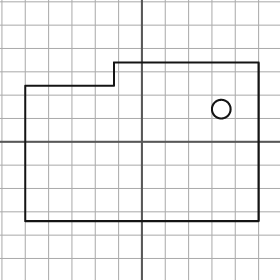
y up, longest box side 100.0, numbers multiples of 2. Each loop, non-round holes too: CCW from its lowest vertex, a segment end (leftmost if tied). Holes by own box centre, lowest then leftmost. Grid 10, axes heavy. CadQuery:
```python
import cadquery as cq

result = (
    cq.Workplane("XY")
    .moveTo(-50.0, -34.0)
    .lineTo(50.0, -34.0)
    .lineTo(50.0, 34.0)
    .lineTo(-12.0, 34.0)
    .lineTo(-12.0, 24.0)
    .lineTo(-50.0, 24.0)
    .close()
    .moveTo(34.0, 14.0)
    .circle(4.0)
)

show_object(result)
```